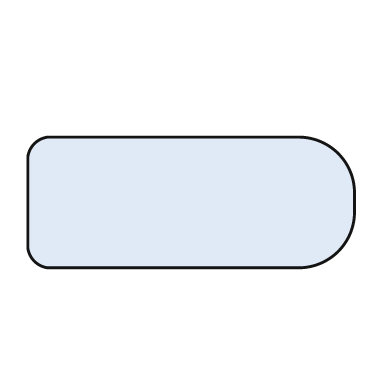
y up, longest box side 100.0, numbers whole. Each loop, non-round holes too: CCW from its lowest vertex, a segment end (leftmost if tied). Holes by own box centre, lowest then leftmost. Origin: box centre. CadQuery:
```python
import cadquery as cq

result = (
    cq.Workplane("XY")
    .moveTo(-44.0, -20.0)
    .lineTo(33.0, -20.0)
    .threePointArc((45.0, -15.0), (50.0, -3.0))
    .lineTo(50.0, 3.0)
    .threePointArc((45.0, 15.0), (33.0, 20.0))
    .lineTo(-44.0, 20.0)
    .threePointArc((-48.0, 18.0), (-50.0, 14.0))
    .lineTo(-50.0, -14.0)
    .threePointArc((-48.0, -18.0), (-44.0, -20.0))
    .close()
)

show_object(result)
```